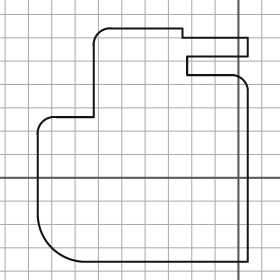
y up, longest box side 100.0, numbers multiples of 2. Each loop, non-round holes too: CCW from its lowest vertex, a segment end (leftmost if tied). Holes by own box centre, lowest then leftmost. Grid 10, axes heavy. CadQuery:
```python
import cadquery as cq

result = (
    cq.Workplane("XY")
    .moveTo(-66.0, -36.0)
    .lineTo(4.0, -36.0)
    .lineTo(4.0, 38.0)
    .threePointArc((2.0, 42.0), (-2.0, 44.0))
    .lineTo(-22.0, 44.0)
    .lineTo(-22.0, 52.0)
    .lineTo(4.0, 52.0)
    .lineTo(4.0, 60.0)
    .lineTo(-24.0, 60.0)
    .lineTo(-24.0, 64.0)
    .lineTo(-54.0, 64.0)
    .threePointArc((-60.0, 62.0), (-62.0, 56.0))
    .lineTo(-62.0, 26.0)
    .lineTo(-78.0, 26.0)
    .threePointArc((-84.0, 24.0), (-86.0, 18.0))
    .lineTo(-86.0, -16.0)
    .threePointArc((-80.0, -30.0), (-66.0, -36.0))
    .close()
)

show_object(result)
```